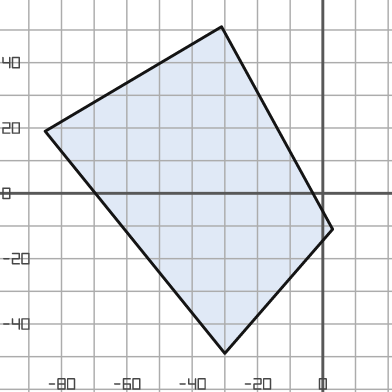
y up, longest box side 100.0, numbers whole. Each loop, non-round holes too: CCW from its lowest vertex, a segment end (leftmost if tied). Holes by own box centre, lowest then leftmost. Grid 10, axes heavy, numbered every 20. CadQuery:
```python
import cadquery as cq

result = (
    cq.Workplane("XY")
    .moveTo(-30.0, -49.0)
    .lineTo(3.0, -11.0)
    .lineTo(-31.0, 51.0)
    .lineTo(-85.0, 19.0)
    .close()
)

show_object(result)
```